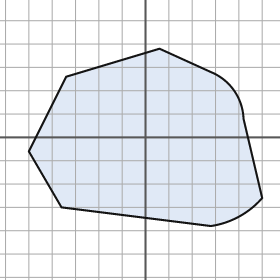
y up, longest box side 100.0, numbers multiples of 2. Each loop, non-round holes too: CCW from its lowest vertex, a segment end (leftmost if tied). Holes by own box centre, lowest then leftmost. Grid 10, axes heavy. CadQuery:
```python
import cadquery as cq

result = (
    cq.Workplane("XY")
    .moveTo(28.0, -38.0)
    .threePointArc((40.0, -34.0), (50.0, -26.0))
    .lineTo(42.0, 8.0)
    .threePointArc((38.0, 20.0), (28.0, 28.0))
    .lineTo(6.0, 38.0)
    .lineTo(-34.0, 26.0)
    .lineTo(-50.0, -6.0)
    .lineTo(-36.0, -30.0)
    .close()
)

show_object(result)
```